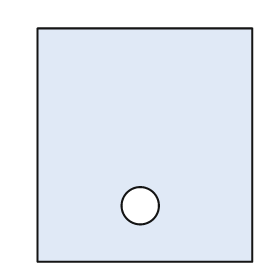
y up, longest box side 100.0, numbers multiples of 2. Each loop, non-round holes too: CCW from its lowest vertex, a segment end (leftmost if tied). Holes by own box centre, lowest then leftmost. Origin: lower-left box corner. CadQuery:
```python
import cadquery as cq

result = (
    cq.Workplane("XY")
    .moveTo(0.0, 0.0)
    .lineTo(92.0, 0.0)
    .lineTo(92.0, 100.0)
    .lineTo(0.0, 100.0)
    .close()
    .moveTo(44.0, 24.0)
    .circle(8.0)
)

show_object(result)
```